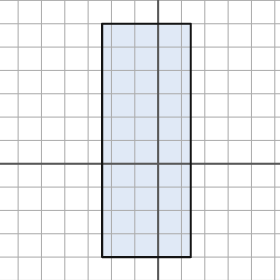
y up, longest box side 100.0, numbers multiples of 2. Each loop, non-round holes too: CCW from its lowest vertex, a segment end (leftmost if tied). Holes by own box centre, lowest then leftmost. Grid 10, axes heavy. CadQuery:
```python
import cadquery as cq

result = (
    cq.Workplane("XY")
    .moveTo(-24.0, -40.0)
    .lineTo(14.0, -40.0)
    .lineTo(14.0, 60.0)
    .lineTo(-24.0, 60.0)
    .close()
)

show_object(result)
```